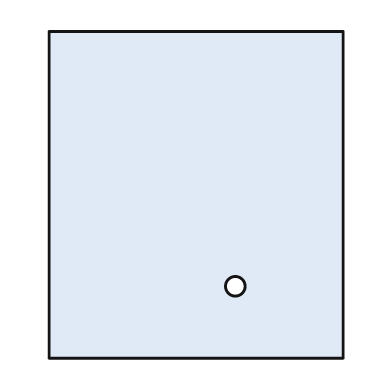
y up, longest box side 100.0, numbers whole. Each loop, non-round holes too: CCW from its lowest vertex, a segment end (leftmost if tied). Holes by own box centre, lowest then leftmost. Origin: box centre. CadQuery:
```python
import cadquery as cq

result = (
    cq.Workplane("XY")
    .moveTo(-45.0, -50.0)
    .lineTo(45.0, -50.0)
    .lineTo(45.0, 50.0)
    .lineTo(-45.0, 50.0)
    .close()
    .moveTo(12.0, -28.0)
    .circle(3.0)
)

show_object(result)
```